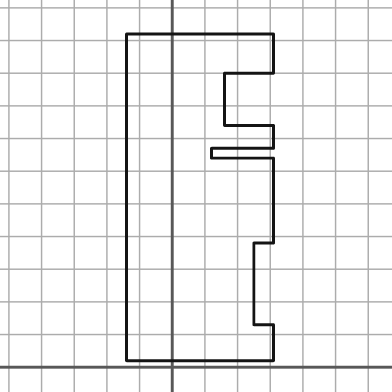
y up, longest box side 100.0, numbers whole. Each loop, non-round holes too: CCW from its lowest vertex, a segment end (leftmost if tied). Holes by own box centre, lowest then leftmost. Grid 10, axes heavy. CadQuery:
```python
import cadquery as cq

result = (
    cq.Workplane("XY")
    .moveTo(-14.0, 2.0)
    .lineTo(31.0, 2.0)
    .lineTo(31.0, 13.0)
    .lineTo(25.0, 13.0)
    .lineTo(25.0, 38.0)
    .lineTo(31.0, 38.0)
    .lineTo(31.0, 64.0)
    .lineTo(12.0, 64.0)
    .lineTo(12.0, 67.0)
    .lineTo(31.0, 67.0)
    .lineTo(31.0, 74.0)
    .lineTo(16.0, 74.0)
    .lineTo(16.0, 90.0)
    .lineTo(31.0, 90.0)
    .lineTo(31.0, 102.0)
    .lineTo(-14.0, 102.0)
    .close()
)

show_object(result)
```